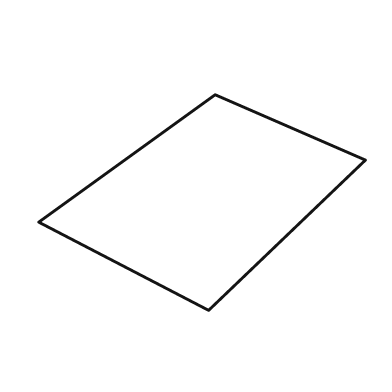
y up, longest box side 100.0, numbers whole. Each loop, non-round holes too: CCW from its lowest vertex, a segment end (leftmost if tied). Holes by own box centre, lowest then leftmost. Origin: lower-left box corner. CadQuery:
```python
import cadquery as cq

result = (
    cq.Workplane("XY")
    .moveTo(52.0, 0.0)
    .lineTo(100.0, 46.0)
    .lineTo(54.0, 66.0)
    .lineTo(0.0, 27.0)
    .close()
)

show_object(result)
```